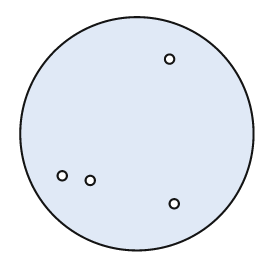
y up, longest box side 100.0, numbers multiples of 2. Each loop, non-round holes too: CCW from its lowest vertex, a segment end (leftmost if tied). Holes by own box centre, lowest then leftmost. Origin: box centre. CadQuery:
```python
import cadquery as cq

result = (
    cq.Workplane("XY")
    .moveTo(0.0, 0.0)
    .circle(50.0)
    .moveTo(16.0, -30.0)
    .circle(2.0)
    .moveTo(-20.0, -20.0)
    .circle(2.0)
    .moveTo(-32.0, -18.0)
    .circle(2.0)
    .moveTo(14.0, 32.0)
    .circle(2.0)
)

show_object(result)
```